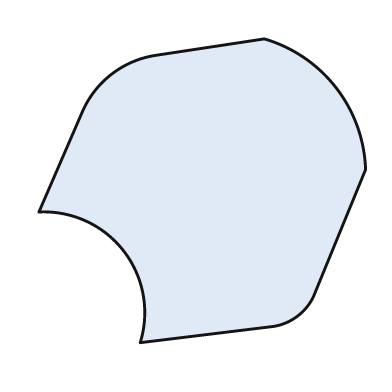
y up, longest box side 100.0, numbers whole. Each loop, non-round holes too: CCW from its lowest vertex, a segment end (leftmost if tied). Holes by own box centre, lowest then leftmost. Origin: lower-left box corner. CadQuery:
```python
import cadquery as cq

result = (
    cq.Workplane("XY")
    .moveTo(31.0, 0.0)
    .lineTo(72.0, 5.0)
    .threePointArc((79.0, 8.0), (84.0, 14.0))
    .lineTo(100.0, 53.0)
    .threePointArc((91.0, 78.0), (69.0, 93.0))
    .lineTo(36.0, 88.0)
    .threePointArc((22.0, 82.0), (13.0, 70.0))
    .lineTo(0.0, 40.0)
    .threePointArc((26.0, 28.0), (31.0, 0.0))
    .close()
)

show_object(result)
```